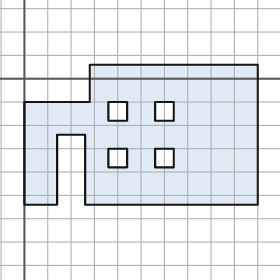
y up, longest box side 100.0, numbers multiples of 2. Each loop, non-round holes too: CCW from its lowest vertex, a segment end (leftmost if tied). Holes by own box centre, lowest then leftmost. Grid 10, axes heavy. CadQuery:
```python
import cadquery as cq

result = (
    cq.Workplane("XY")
    .moveTo(0.0, -54.0)
    .lineTo(14.0, -54.0)
    .lineTo(14.0, -24.0)
    .lineTo(26.0, -24.0)
    .lineTo(26.0, -54.0)
    .lineTo(100.0, -54.0)
    .lineTo(100.0, 6.0)
    .lineTo(28.0, 6.0)
    .lineTo(28.0, -10.0)
    .lineTo(0.0, -10.0)
    .close()
    .moveTo(36.0, -38.0)
    .lineTo(44.0, -38.0)
    .lineTo(44.0, -30.0)
    .lineTo(36.0, -30.0)
    .close()
    .moveTo(56.0, -38.0)
    .lineTo(64.0, -38.0)
    .lineTo(64.0, -30.0)
    .lineTo(56.0, -30.0)
    .close()
    .moveTo(36.0, -18.0)
    .lineTo(44.0, -18.0)
    .lineTo(44.0, -10.0)
    .lineTo(36.0, -10.0)
    .close()
    .moveTo(56.0, -18.0)
    .lineTo(64.0, -18.0)
    .lineTo(64.0, -10.0)
    .lineTo(56.0, -10.0)
    .close()
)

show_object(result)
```